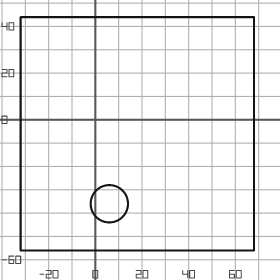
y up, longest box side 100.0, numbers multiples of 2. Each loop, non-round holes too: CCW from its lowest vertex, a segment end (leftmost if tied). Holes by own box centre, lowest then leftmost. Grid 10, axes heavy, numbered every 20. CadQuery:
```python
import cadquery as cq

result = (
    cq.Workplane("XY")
    .moveTo(-32.0, -56.0)
    .lineTo(68.0, -56.0)
    .lineTo(68.0, 44.0)
    .lineTo(-32.0, 44.0)
    .close()
    .moveTo(6.0, -36.0)
    .circle(8.0)
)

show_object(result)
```